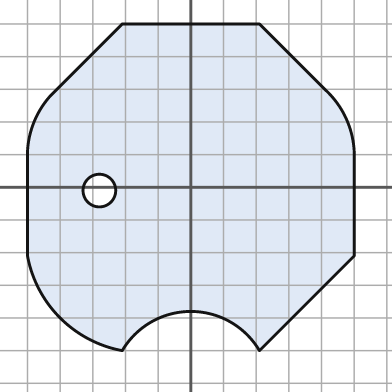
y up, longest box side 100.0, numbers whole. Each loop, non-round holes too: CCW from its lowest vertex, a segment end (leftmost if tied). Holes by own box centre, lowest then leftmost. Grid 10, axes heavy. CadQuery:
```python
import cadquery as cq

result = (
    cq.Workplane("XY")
    .moveTo(-21.0, -50.0)
    .threePointArc((0.0, -38.0), (21.0, -50.0))
    .lineTo(50.0, -21.0)
    .lineTo(50.0, 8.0)
    .threePointArc((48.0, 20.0), (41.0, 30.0))
    .lineTo(21.0, 50.0)
    .lineTo(-21.0, 50.0)
    .lineTo(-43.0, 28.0)
    .threePointArc((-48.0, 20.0), (-50.0, 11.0))
    .lineTo(-50.0, -21.0)
    .threePointArc((-40.0, -40.0), (-21.0, -50.0))
    .close()
    .moveTo(-28.0, -1.0)
    .circle(5.0)
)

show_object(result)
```